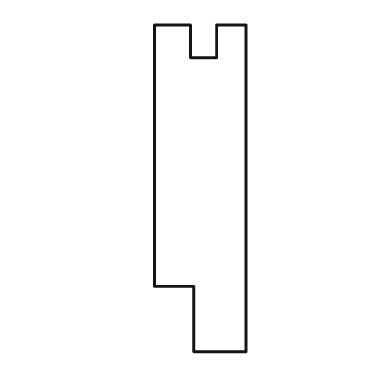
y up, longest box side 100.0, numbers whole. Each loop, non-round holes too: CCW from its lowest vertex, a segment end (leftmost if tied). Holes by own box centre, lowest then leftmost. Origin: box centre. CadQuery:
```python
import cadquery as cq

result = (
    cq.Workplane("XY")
    .moveTo(-2.0, -50.0)
    .lineTo(14.0, -50.0)
    .lineTo(14.0, 50.0)
    .lineTo(5.0, 50.0)
    .lineTo(5.0, 40.0)
    .lineTo(-3.0, 40.0)
    .lineTo(-3.0, 50.0)
    .lineTo(-14.0, 50.0)
    .lineTo(-14.0, -30.0)
    .lineTo(-2.0, -30.0)
    .close()
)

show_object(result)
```